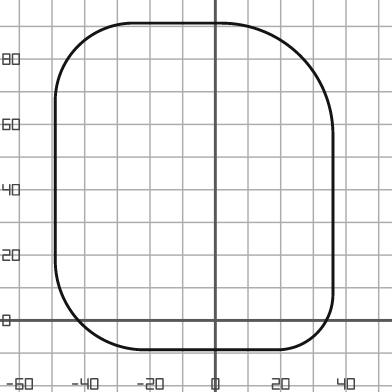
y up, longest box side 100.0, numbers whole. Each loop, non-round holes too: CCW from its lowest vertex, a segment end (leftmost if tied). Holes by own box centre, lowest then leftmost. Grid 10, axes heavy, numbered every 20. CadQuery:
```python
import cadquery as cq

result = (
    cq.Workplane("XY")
    .moveTo(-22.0, -9.0)
    .lineTo(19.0, -9.0)
    .threePointArc((31.0, -4.0), (36.0, 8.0))
    .lineTo(36.0, 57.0)
    .threePointArc((26.0, 81.0), (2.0, 91.0))
    .lineTo(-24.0, 91.0)
    .threePointArc((-42.0, 84.0), (-49.0, 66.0))
    .lineTo(-49.0, 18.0)
    .threePointArc((-41.0, -1.0), (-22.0, -9.0))
    .close()
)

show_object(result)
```